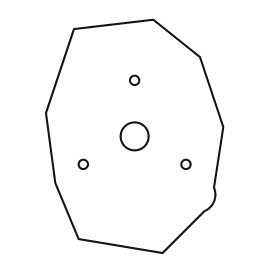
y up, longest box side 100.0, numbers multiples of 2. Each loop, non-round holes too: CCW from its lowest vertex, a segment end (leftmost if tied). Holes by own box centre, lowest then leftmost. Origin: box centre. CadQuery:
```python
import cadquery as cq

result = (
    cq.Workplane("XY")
    .moveTo(12.0, -50.0)
    .lineTo(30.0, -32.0)
    .threePointArc((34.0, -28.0), (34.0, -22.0))
    .lineTo(38.0, 4.0)
    .lineTo(28.0, 34.0)
    .lineTo(8.0, 50.0)
    .lineTo(-26.0, 46.0)
    .lineTo(-38.0, 10.0)
    .lineTo(-34.0, -20.0)
    .lineTo(-24.0, -44.0)
    .close()
    .moveTo(-22.0, -12.0)
    .circle(2.0)
    .moveTo(22.0, -12.0)
    .circle(2.0)
    .moveTo(0.0, 0.0)
    .circle(6.0)
    .moveTo(0.0, 24.0)
    .circle(2.0)
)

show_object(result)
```